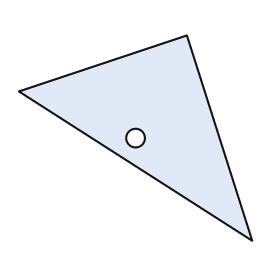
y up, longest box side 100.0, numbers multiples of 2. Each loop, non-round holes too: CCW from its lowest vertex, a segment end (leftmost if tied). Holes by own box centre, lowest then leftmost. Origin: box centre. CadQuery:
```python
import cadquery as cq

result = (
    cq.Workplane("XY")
    .moveTo(50.0, -44.0)
    .lineTo(22.0, 44.0)
    .lineTo(-50.0, 20.0)
    .close()
    .moveTo(0.0, 0.0)
    .circle(4.0)
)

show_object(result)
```